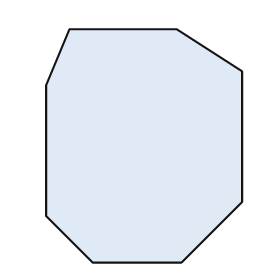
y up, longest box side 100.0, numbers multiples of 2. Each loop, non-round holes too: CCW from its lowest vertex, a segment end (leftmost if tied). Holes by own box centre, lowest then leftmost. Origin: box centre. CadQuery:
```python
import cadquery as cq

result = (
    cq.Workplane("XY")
    .moveTo(-22.0, -50.0)
    .lineTo(16.0, -50.0)
    .lineTo(42.0, -24.0)
    .lineTo(42.0, 32.0)
    .lineTo(14.0, 50.0)
    .lineTo(-32.0, 50.0)
    .lineTo(-42.0, 26.0)
    .lineTo(-42.0, -30.0)
    .close()
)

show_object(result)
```